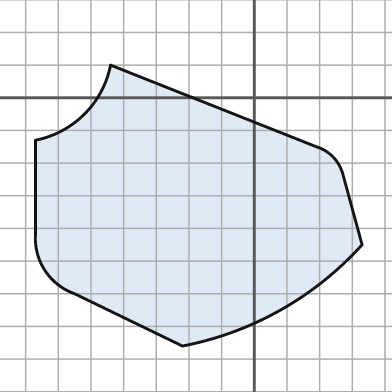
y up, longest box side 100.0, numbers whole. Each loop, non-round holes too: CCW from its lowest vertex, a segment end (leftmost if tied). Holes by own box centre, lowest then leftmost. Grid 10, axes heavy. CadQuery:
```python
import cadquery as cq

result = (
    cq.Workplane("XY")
    .moveTo(-22.0, -76.0)
    .threePointArc((8.0, -65.0), (33.0, -45.0))
    .lineTo(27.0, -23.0)
    .threePointArc((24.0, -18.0), (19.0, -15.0))
    .lineTo(-44.0, 10.0)
    .threePointArc((-52.0, -5.0), (-67.0, -13.0))
    .lineTo(-67.0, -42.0)
    .threePointArc((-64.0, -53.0), (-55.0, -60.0))
    .close()
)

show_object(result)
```